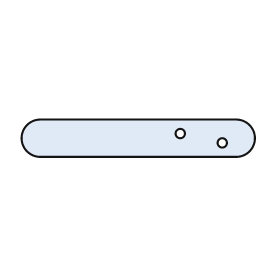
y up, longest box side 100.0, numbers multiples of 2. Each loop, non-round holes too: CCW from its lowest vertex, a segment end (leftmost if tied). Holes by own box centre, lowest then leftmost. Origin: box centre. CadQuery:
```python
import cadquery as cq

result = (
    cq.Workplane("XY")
    .moveTo(-42.0, -8.0)
    .lineTo(42.0, -8.0)
    .threePointArc((50.0, 0.0), (42.0, 8.0))
    .lineTo(-42.0, 8.0)
    .threePointArc((-50.0, 0.0), (-42.0, -8.0))
    .close()
    .moveTo(36.0, -2.0)
    .circle(2.0)
    .moveTo(18.0, 2.0)
    .circle(2.0)
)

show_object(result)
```